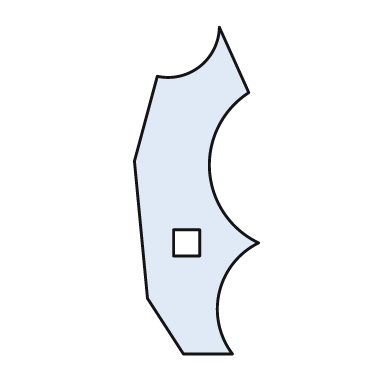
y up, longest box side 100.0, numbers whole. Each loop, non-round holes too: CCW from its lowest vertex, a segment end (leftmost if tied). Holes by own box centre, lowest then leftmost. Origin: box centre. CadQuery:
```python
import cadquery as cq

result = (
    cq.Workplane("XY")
    .moveTo(-4.0, -50.0)
    .lineTo(11.0, -50.0)
    .threePointArc((7.0, -31.0), (19.0, -16.0))
    .threePointArc((4.0, 6.0), (16.0, 30.0))
    .lineTo(7.0, 50.0)
    .threePointArc((1.0, 38.0), (-12.0, 35.0))
    .lineTo(-19.0, 9.0)
    .lineTo(-15.0, -33.0)
    .close()
    .moveTo(-7.0, -20.0)
    .lineTo(1.0, -20.0)
    .lineTo(1.0, -12.0)
    .lineTo(-7.0, -12.0)
    .close()
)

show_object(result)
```